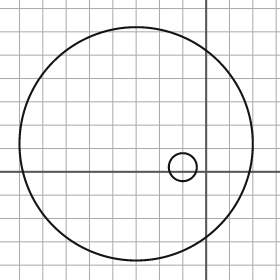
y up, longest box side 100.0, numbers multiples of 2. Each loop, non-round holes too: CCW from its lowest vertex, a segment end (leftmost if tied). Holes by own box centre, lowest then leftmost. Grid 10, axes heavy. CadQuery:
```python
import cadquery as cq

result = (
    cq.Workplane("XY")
    .moveTo(-30.0, 12.0)
    .circle(50.0)
    .moveTo(-10.0, 2.0)
    .circle(6.0)
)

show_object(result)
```